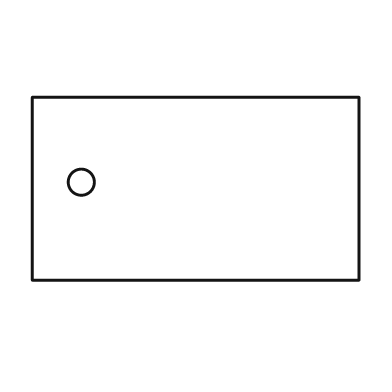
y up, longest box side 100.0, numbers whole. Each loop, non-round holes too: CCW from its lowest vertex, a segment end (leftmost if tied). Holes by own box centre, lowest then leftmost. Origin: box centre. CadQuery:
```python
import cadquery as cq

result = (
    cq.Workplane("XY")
    .moveTo(-50.0, -28.0)
    .lineTo(50.0, -28.0)
    .lineTo(50.0, 28.0)
    .lineTo(-50.0, 28.0)
    .close()
    .moveTo(-35.0, 2.0)
    .circle(4.0)
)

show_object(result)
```